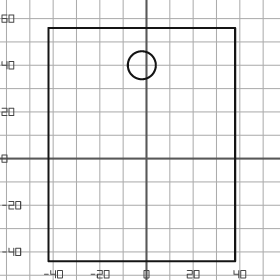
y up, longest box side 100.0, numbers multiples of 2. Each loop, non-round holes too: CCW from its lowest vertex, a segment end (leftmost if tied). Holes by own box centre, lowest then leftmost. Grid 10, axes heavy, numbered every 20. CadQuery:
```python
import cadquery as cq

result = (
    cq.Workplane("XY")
    .moveTo(-42.0, -44.0)
    .lineTo(38.0, -44.0)
    .lineTo(38.0, 56.0)
    .lineTo(-42.0, 56.0)
    .close()
    .moveTo(-2.0, 40.0)
    .circle(6.0)
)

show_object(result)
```